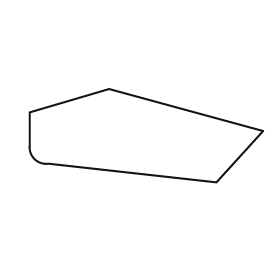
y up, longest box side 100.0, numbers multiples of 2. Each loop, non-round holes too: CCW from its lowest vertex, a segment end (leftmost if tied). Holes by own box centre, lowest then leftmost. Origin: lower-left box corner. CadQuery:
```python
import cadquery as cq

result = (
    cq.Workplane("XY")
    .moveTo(80.0, 0.0)
    .lineTo(100.0, 22.0)
    .lineTo(34.0, 40.0)
    .lineTo(0.0, 30.0)
    .lineTo(0.0, 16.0)
    .threePointArc((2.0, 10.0), (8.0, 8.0))
    .close()
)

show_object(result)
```